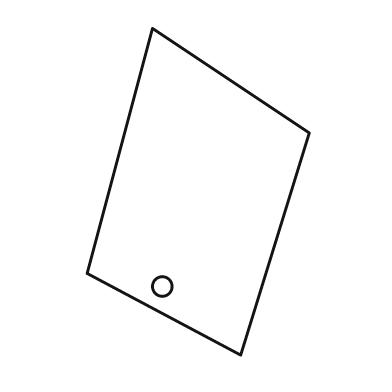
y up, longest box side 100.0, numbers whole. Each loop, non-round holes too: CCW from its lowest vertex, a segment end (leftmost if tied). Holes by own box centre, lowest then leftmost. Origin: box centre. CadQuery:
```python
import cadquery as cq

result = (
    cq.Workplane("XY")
    .moveTo(13.0, -50.0)
    .lineTo(34.0, 18.0)
    .lineTo(-14.0, 50.0)
    .lineTo(-34.0, -25.0)
    .close()
    .moveTo(-11.0, -29.0)
    .circle(3.0)
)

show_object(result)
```